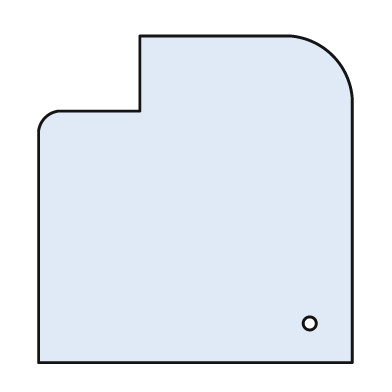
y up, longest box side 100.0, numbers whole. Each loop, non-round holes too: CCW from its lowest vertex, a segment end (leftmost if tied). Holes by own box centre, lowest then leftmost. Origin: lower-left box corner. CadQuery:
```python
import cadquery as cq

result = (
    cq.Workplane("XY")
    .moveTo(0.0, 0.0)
    .lineTo(96.0, 0.0)
    .lineTo(96.0, 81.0)
    .threePointArc((90.0, 94.0), (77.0, 100.0))
    .lineTo(31.0, 100.0)
    .lineTo(31.0, 77.0)
    .lineTo(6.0, 77.0)
    .threePointArc((2.0, 75.0), (0.0, 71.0))
    .close()
    .moveTo(83.0, 12.0)
    .circle(2.0)
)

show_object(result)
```